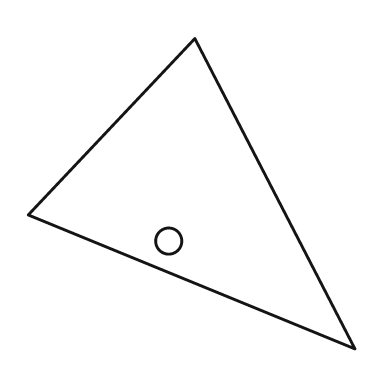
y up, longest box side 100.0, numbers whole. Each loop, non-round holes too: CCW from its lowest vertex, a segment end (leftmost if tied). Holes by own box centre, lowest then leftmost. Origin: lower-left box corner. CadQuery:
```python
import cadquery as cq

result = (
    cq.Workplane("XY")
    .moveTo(100.0, 0.0)
    .lineTo(51.0, 95.0)
    .lineTo(0.0, 41.0)
    .close()
    .moveTo(43.0, 33.0)
    .circle(4.0)
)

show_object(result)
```